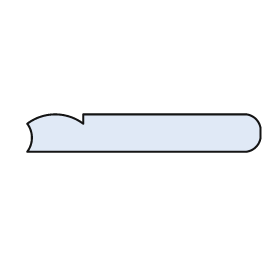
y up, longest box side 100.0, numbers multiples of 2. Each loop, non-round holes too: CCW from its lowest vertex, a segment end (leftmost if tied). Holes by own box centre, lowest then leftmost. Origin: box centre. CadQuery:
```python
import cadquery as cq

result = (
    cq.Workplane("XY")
    .moveTo(-50.0, -8.0)
    .lineTo(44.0, -8.0)
    .threePointArc((48.0, -6.0), (50.0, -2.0))
    .lineTo(50.0, 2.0)
    .threePointArc((48.0, 6.0), (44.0, 8.0))
    .lineTo(-26.0, 8.0)
    .lineTo(-26.0, 4.0)
    .threePointArc((-38.0, 8.0), (-50.0, 4.0))
    .threePointArc((-48.0, -2.0), (-50.0, -8.0))
    .close()
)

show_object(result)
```